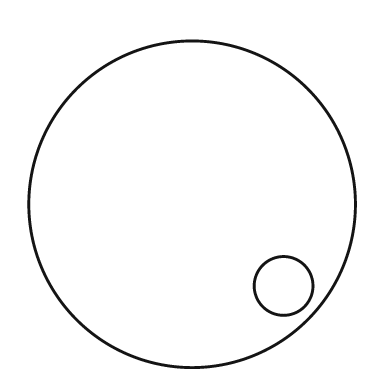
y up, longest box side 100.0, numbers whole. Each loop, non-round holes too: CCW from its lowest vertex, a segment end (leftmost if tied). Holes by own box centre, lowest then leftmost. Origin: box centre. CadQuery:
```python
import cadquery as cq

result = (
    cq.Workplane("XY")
    .moveTo(0.0, 0.0)
    .circle(50.0)
    .moveTo(28.0, -25.0)
    .circle(9.0)
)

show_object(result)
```